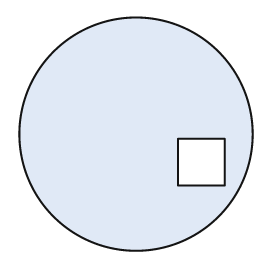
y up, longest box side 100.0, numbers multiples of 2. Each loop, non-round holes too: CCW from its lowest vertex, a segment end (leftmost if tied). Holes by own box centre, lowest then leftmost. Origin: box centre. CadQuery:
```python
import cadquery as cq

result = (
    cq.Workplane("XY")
    .moveTo(0.0, 0.0)
    .circle(50.0)
    .moveTo(18.0, -22.0)
    .lineTo(38.0, -22.0)
    .lineTo(38.0, -2.0)
    .lineTo(18.0, -2.0)
    .close()
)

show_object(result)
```